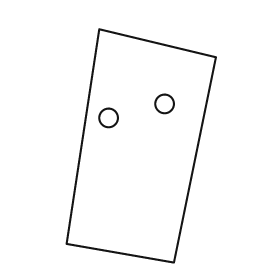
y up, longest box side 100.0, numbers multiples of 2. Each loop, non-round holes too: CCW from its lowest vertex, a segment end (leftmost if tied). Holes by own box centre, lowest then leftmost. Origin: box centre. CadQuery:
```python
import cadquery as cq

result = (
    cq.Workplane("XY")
    .moveTo(14.0, -50.0)
    .lineTo(32.0, 38.0)
    .lineTo(-18.0, 50.0)
    .lineTo(-32.0, -42.0)
    .close()
    .moveTo(-14.0, 12.0)
    .circle(4.0)
    .moveTo(10.0, 18.0)
    .circle(4.0)
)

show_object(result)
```